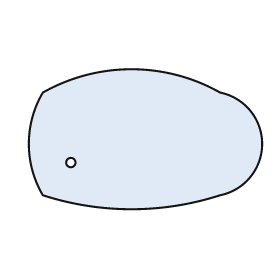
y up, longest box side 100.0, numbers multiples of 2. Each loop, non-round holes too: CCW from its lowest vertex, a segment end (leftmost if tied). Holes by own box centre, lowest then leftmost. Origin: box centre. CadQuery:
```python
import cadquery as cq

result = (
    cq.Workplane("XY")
    .moveTo(-44.0, -24.0)
    .threePointArc((-6.0, -30.0), (32.0, -24.0))
    .threePointArc((50.0, -2.0), (32.0, 20.0))
    .threePointArc((-6.0, 30.0), (-44.0, 20.0))
    .threePointArc((-50.0, -2.0), (-44.0, -24.0))
    .close()
    .moveTo(-32.0, -10.0)
    .circle(2.0)
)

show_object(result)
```